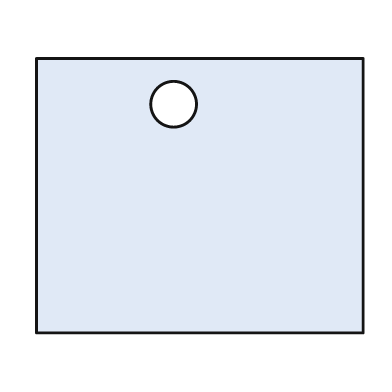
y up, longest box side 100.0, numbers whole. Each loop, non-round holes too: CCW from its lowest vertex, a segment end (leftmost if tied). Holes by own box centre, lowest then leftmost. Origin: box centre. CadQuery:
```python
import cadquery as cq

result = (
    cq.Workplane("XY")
    .moveTo(-50.0, -42.0)
    .lineTo(50.0, -42.0)
    .lineTo(50.0, 42.0)
    .lineTo(-50.0, 42.0)
    .close()
    .moveTo(-8.0, 28.0)
    .circle(7.0)
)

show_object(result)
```